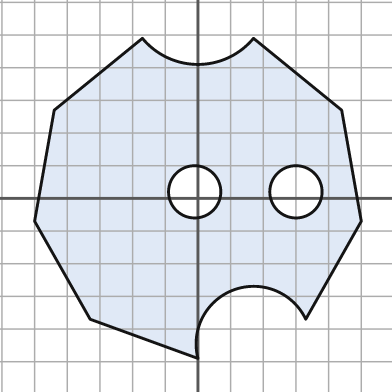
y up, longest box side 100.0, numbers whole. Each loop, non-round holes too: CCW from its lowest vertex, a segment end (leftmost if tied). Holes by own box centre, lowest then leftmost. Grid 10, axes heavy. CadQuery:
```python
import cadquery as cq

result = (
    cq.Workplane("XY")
    .moveTo(0.0, -49.0)
    .threePointArc((11.0, -28.0), (33.0, -37.0))
    .lineTo(50.0, -7.0)
    .lineTo(44.0, 27.0)
    .lineTo(17.0, 49.0)
    .threePointArc((0.0, 41.0), (-17.0, 49.0))
    .lineTo(-44.0, 27.0)
    .lineTo(-50.0, -7.0)
    .lineTo(-33.0, -37.0)
    .close()
    .moveTo(-1.0, 2.0)
    .circle(8.0)
    .moveTo(30.0, 2.0)
    .circle(8.0)
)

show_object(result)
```